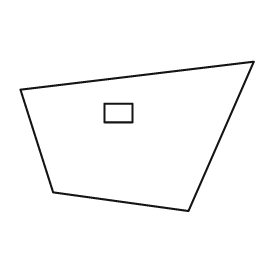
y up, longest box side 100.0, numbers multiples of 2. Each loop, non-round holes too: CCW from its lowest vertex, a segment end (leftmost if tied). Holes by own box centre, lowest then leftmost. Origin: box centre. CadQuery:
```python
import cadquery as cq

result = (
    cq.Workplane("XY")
    .moveTo(22.0, -32.0)
    .lineTo(50.0, 32.0)
    .lineTo(-50.0, 20.0)
    .lineTo(-36.0, -24.0)
    .close()
    .moveTo(-14.0, 6.0)
    .lineTo(-2.0, 6.0)
    .lineTo(-2.0, 14.0)
    .lineTo(-14.0, 14.0)
    .close()
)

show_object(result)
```